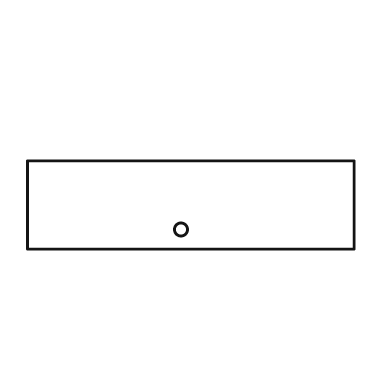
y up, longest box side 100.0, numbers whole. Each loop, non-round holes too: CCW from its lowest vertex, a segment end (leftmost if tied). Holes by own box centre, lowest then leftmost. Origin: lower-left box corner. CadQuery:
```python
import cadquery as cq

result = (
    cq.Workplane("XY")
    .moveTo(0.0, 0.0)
    .lineTo(100.0, 0.0)
    .lineTo(100.0, 27.0)
    .lineTo(0.0, 27.0)
    .close()
    .moveTo(47.0, 6.0)
    .circle(2.0)
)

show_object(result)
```